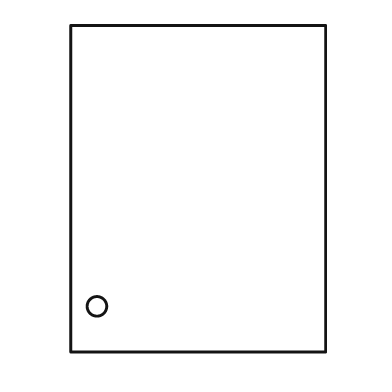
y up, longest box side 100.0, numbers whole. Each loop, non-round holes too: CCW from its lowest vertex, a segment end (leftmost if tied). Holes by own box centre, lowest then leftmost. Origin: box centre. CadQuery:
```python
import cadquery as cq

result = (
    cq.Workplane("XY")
    .moveTo(-39.0, -50.0)
    .lineTo(39.0, -50.0)
    .lineTo(39.0, 50.0)
    .lineTo(-39.0, 50.0)
    .close()
    .moveTo(-31.0, -36.0)
    .circle(3.0)
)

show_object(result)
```